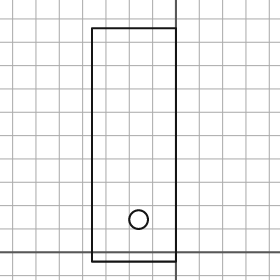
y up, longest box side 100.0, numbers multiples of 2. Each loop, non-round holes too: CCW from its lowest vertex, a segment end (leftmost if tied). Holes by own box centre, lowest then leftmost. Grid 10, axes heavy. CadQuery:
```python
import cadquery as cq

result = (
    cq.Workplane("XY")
    .moveTo(-36.0, -4.0)
    .lineTo(0.0, -4.0)
    .lineTo(0.0, 96.0)
    .lineTo(-36.0, 96.0)
    .close()
    .moveTo(-16.0, 14.0)
    .circle(4.0)
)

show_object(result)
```